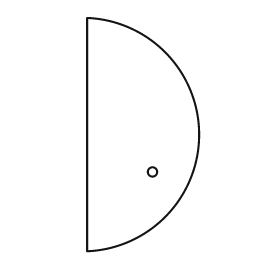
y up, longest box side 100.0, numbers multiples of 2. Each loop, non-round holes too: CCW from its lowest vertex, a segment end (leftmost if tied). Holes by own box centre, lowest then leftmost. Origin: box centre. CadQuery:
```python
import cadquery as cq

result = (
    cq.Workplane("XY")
    .moveTo(-24.0, -50.0)
    .threePointArc((24.0, 0.0), (-24.0, 50.0))
    .close()
    .moveTo(4.0, -16.0)
    .circle(2.0)
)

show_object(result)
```